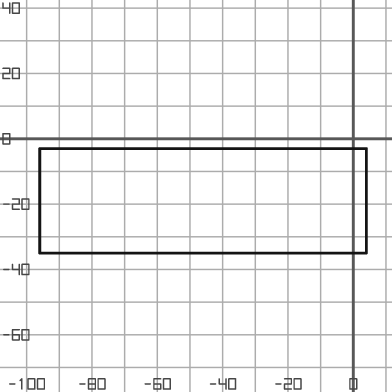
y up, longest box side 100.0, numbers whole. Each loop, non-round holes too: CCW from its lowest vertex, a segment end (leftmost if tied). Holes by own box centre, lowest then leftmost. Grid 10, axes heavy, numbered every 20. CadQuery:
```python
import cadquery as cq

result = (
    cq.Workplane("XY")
    .moveTo(-96.0, -35.0)
    .lineTo(4.0, -35.0)
    .lineTo(4.0, -3.0)
    .lineTo(-96.0, -3.0)
    .close()
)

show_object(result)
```